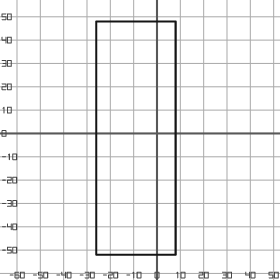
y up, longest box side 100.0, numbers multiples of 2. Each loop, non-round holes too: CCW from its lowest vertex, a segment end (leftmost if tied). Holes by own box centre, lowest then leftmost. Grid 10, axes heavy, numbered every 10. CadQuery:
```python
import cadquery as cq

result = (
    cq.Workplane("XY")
    .moveTo(-26.0, -52.0)
    .lineTo(8.0, -52.0)
    .lineTo(8.0, 48.0)
    .lineTo(-26.0, 48.0)
    .close()
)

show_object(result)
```